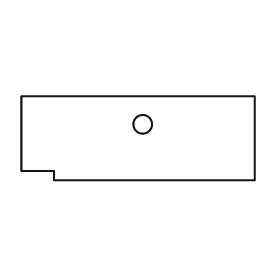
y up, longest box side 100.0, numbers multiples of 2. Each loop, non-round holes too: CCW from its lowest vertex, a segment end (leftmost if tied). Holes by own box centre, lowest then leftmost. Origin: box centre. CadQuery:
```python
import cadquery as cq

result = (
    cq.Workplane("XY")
    .moveTo(-36.0, -18.0)
    .lineTo(50.0, -18.0)
    .lineTo(50.0, 18.0)
    .lineTo(-50.0, 18.0)
    .lineTo(-50.0, -14.0)
    .lineTo(-36.0, -14.0)
    .close()
    .moveTo(2.0, 6.0)
    .circle(4.0)
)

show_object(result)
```